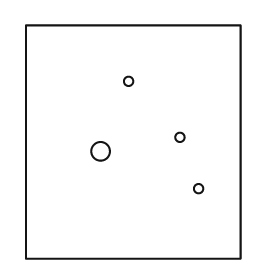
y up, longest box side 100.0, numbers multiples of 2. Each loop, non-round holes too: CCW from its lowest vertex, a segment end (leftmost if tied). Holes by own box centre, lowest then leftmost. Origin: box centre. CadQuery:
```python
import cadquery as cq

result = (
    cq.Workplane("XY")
    .moveTo(-46.0, -50.0)
    .lineTo(46.0, -50.0)
    .lineTo(46.0, 50.0)
    .lineTo(-46.0, 50.0)
    .close()
    .moveTo(28.0, -20.0)
    .circle(2.0)
    .moveTo(-14.0, -4.0)
    .circle(4.0)
    .moveTo(20.0, 2.0)
    .circle(2.0)
    .moveTo(-2.0, 26.0)
    .circle(2.0)
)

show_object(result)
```